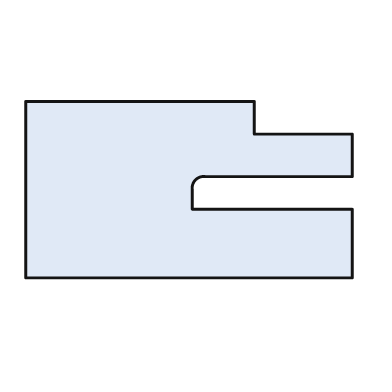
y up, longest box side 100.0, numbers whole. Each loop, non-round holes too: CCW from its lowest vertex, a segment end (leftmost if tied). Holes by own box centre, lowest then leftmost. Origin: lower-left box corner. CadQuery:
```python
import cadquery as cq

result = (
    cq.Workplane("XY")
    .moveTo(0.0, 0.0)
    .lineTo(100.0, 0.0)
    .lineTo(100.0, 21.0)
    .lineTo(51.0, 21.0)
    .lineTo(51.0, 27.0)
    .threePointArc((52.0, 30.0), (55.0, 31.0))
    .lineTo(100.0, 31.0)
    .lineTo(100.0, 44.0)
    .lineTo(70.0, 44.0)
    .lineTo(70.0, 54.0)
    .lineTo(0.0, 54.0)
    .close()
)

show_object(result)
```